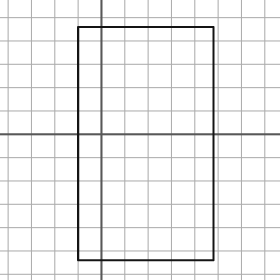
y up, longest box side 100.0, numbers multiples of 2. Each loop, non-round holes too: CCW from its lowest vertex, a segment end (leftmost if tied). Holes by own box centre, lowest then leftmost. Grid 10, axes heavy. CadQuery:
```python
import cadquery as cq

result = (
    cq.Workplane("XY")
    .moveTo(-10.0, -54.0)
    .lineTo(48.0, -54.0)
    .lineTo(48.0, 46.0)
    .lineTo(-10.0, 46.0)
    .close()
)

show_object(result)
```